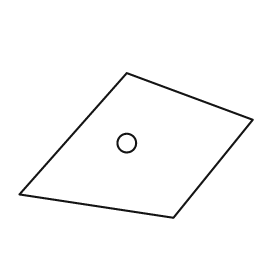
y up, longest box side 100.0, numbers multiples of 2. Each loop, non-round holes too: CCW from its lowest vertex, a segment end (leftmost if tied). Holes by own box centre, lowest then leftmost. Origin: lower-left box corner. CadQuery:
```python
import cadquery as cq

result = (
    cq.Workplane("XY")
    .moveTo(66.0, 0.0)
    .lineTo(100.0, 42.0)
    .lineTo(46.0, 62.0)
    .lineTo(0.0, 10.0)
    .close()
    .moveTo(46.0, 32.0)
    .circle(4.0)
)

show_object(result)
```